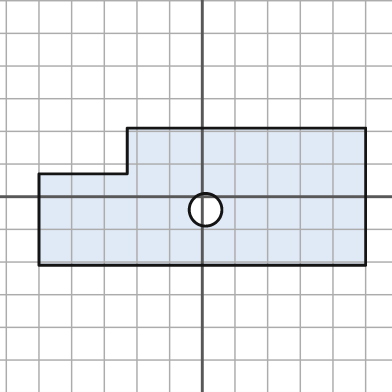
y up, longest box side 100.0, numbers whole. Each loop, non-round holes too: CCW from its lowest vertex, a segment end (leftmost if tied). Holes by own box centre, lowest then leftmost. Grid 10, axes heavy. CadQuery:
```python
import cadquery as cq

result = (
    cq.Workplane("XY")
    .moveTo(-50.0, -21.0)
    .lineTo(50.0, -21.0)
    .lineTo(50.0, 21.0)
    .lineTo(-23.0, 21.0)
    .lineTo(-23.0, 7.0)
    .lineTo(-50.0, 7.0)
    .close()
    .moveTo(1.0, -4.0)
    .circle(5.0)
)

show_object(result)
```